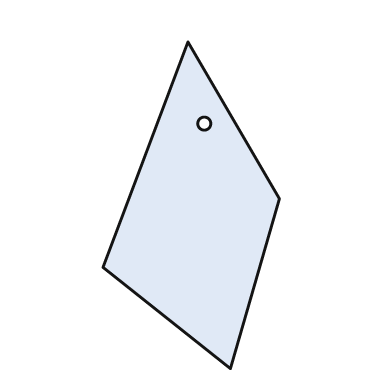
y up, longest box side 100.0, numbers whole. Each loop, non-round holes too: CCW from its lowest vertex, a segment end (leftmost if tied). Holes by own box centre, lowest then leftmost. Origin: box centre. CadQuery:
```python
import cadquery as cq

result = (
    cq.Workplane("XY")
    .moveTo(12.0, -50.0)
    .lineTo(27.0, 2.0)
    .lineTo(-1.0, 50.0)
    .lineTo(-27.0, -19.0)
    .close()
    .moveTo(4.0, 25.0)
    .circle(2.0)
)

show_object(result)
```